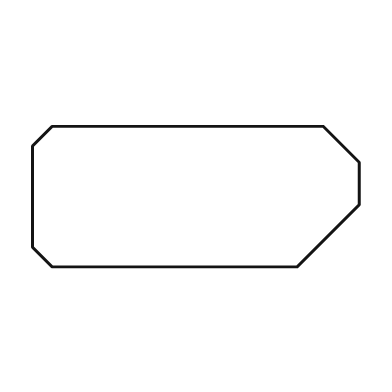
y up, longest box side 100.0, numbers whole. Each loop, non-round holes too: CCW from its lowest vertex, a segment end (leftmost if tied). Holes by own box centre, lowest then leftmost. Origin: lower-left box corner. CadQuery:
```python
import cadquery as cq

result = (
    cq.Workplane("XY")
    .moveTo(6.0, 0.0)
    .lineTo(81.0, 0.0)
    .lineTo(100.0, 19.0)
    .lineTo(100.0, 32.0)
    .lineTo(89.0, 43.0)
    .lineTo(6.0, 43.0)
    .lineTo(0.0, 37.0)
    .lineTo(0.0, 6.0)
    .close()
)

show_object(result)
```